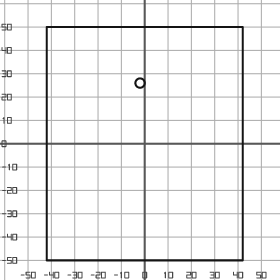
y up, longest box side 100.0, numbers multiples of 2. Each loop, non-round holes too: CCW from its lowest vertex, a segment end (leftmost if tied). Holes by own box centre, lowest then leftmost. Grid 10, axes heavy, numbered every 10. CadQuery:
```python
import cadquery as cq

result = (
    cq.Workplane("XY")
    .moveTo(-42.0, -50.0)
    .lineTo(42.0, -50.0)
    .lineTo(42.0, 50.0)
    .lineTo(-42.0, 50.0)
    .close()
    .moveTo(-2.0, 26.0)
    .circle(2.0)
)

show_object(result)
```